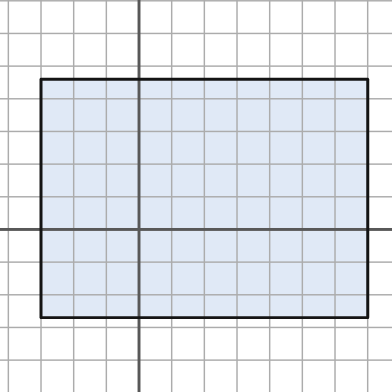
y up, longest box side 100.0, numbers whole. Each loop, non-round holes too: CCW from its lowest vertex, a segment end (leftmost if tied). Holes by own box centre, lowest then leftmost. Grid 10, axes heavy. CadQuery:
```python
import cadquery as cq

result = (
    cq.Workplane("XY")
    .moveTo(-30.0, -27.0)
    .lineTo(70.0, -27.0)
    .lineTo(70.0, 46.0)
    .lineTo(-30.0, 46.0)
    .close()
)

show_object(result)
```